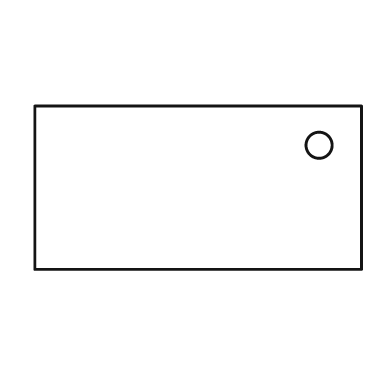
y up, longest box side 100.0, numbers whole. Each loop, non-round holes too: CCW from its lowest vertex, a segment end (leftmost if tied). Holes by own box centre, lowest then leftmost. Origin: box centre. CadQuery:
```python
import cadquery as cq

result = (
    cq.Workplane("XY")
    .moveTo(-50.0, -25.0)
    .lineTo(50.0, -25.0)
    .lineTo(50.0, 25.0)
    .lineTo(-50.0, 25.0)
    .close()
    .moveTo(37.0, 13.0)
    .circle(4.0)
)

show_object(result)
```